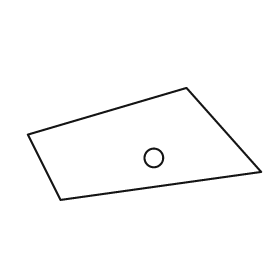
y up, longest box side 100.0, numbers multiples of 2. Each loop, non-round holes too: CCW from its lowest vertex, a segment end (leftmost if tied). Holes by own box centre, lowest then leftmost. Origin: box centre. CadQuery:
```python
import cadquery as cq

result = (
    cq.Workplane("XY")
    .moveTo(-36.0, -24.0)
    .lineTo(50.0, -12.0)
    .lineTo(18.0, 24.0)
    .lineTo(-50.0, 4.0)
    .close()
    .moveTo(4.0, -6.0)
    .circle(4.0)
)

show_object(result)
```